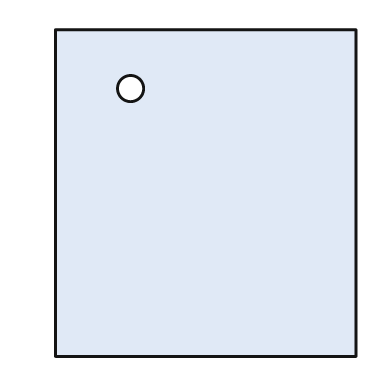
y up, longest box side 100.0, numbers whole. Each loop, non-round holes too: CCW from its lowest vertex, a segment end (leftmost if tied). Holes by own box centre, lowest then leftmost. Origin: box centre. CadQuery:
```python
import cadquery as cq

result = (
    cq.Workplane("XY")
    .moveTo(-46.0, -50.0)
    .lineTo(46.0, -50.0)
    .lineTo(46.0, 50.0)
    .lineTo(-46.0, 50.0)
    .close()
    .moveTo(-23.0, 32.0)
    .circle(4.0)
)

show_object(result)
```